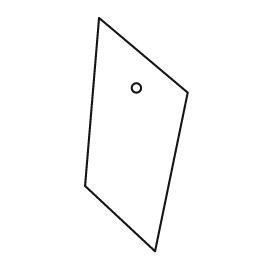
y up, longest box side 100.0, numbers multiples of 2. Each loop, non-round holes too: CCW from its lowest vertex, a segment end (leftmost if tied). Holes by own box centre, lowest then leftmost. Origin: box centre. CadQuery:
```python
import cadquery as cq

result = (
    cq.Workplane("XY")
    .moveTo(8.0, -50.0)
    .lineTo(22.0, 18.0)
    .lineTo(-16.0, 50.0)
    .lineTo(-22.0, -22.0)
    .close()
    .moveTo(0.0, 20.0)
    .circle(2.0)
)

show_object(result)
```